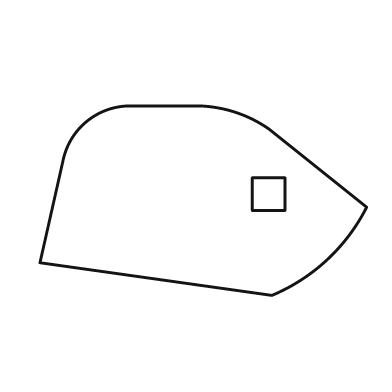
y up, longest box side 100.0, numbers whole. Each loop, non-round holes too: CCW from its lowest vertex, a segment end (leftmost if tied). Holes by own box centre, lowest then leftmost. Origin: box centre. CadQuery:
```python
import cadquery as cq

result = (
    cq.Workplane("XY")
    .moveTo(21.0, -29.0)
    .threePointArc((38.0, -18.0), (50.0, -2.0))
    .lineTo(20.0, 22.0)
    .threePointArc((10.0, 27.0), (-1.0, 29.0))
    .lineTo(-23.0, 29.0)
    .threePointArc((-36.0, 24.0), (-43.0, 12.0))
    .lineTo(-50.0, -19.0)
    .close()
    .moveTo(15.0, -3.0)
    .lineTo(25.0, -3.0)
    .lineTo(25.0, 7.0)
    .lineTo(15.0, 7.0)
    .close()
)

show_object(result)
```